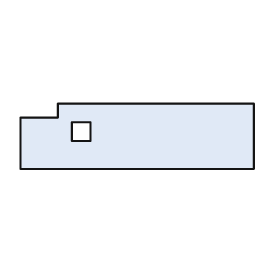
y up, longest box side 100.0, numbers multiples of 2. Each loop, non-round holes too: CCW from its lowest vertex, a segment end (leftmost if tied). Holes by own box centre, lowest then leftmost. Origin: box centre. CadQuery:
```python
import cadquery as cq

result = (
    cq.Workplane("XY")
    .moveTo(-50.0, -14.0)
    .lineTo(50.0, -14.0)
    .lineTo(50.0, 14.0)
    .lineTo(-34.0, 14.0)
    .lineTo(-34.0, 8.0)
    .lineTo(-50.0, 8.0)
    .close()
    .moveTo(-28.0, -2.0)
    .lineTo(-20.0, -2.0)
    .lineTo(-20.0, 6.0)
    .lineTo(-28.0, 6.0)
    .close()
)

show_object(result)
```